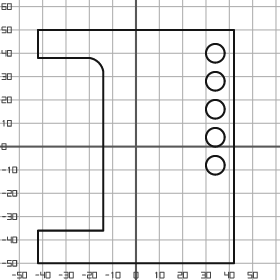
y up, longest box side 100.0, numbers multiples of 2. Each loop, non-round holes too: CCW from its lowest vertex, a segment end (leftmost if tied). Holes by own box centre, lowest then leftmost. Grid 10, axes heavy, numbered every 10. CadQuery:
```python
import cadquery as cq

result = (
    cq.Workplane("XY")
    .moveTo(-42.0, -50.0)
    .lineTo(42.0, -50.0)
    .lineTo(42.0, 50.0)
    .lineTo(-42.0, 50.0)
    .lineTo(-42.0, 38.0)
    .lineTo(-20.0, 38.0)
    .threePointArc((-16.0, 36.0), (-14.0, 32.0))
    .lineTo(-14.0, -36.0)
    .lineTo(-42.0, -36.0)
    .close()
    .moveTo(34.0, -8.0)
    .circle(4.0)
    .moveTo(34.0, 4.0)
    .circle(4.0)
    .moveTo(34.0, 16.0)
    .circle(4.0)
    .moveTo(34.0, 28.0)
    .circle(4.0)
    .moveTo(34.0, 40.0)
    .circle(4.0)
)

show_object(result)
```